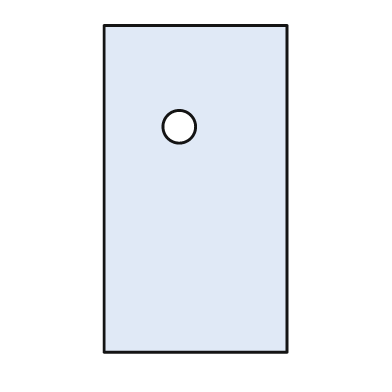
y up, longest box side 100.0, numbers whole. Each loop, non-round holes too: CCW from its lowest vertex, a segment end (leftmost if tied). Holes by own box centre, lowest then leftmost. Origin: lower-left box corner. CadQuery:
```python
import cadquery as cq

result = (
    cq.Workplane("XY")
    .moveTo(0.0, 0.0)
    .lineTo(56.0, 0.0)
    .lineTo(56.0, 100.0)
    .lineTo(0.0, 100.0)
    .close()
    .moveTo(23.0, 69.0)
    .circle(5.0)
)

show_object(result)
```